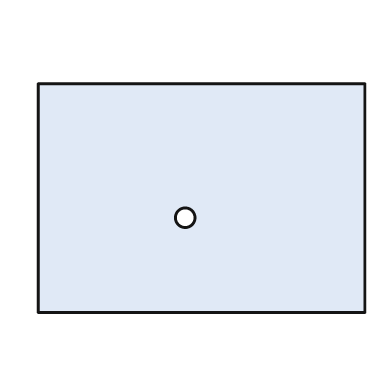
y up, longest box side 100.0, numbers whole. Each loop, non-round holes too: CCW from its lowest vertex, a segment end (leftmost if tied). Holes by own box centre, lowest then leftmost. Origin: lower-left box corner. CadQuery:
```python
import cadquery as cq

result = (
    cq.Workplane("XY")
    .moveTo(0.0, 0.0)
    .lineTo(100.0, 0.0)
    .lineTo(100.0, 70.0)
    .lineTo(0.0, 70.0)
    .close()
    .moveTo(45.0, 29.0)
    .circle(3.0)
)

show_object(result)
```